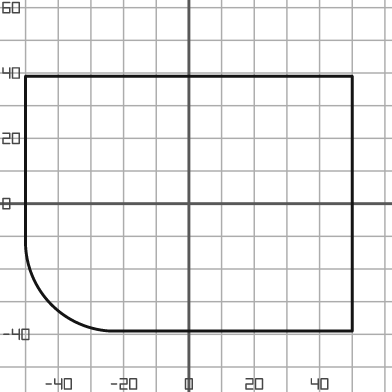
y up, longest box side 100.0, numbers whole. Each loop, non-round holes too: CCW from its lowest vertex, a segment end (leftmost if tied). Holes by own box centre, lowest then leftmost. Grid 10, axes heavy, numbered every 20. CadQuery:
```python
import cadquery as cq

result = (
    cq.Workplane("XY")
    .moveTo(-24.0, -39.0)
    .lineTo(50.0, -39.0)
    .lineTo(50.0, 39.0)
    .lineTo(-50.0, 39.0)
    .lineTo(-50.0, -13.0)
    .threePointArc((-42.0, -31.0), (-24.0, -39.0))
    .close()
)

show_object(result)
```